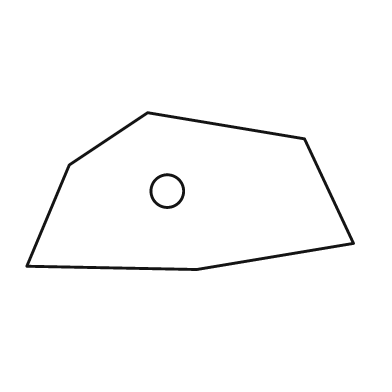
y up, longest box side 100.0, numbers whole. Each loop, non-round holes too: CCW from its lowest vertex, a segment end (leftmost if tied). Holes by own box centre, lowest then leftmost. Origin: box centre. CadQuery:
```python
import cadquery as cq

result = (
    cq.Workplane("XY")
    .moveTo(2.0, -24.0)
    .lineTo(50.0, -16.0)
    .lineTo(35.0, 16.0)
    .lineTo(-13.0, 24.0)
    .lineTo(-37.0, 8.0)
    .lineTo(-50.0, -23.0)
    .close()
    .moveTo(-7.0, 0.0)
    .circle(5.0)
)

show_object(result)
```